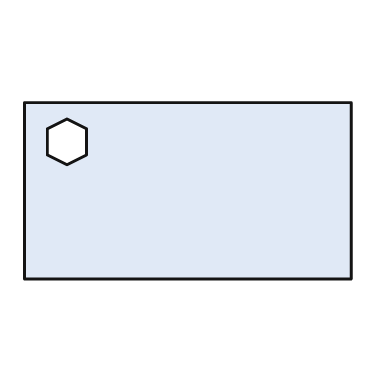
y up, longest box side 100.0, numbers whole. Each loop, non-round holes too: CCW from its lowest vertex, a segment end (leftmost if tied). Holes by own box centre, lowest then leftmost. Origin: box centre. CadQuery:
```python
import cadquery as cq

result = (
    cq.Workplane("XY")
    .moveTo(-50.0, -27.0)
    .lineTo(50.0, -27.0)
    .lineTo(50.0, 27.0)
    .lineTo(-50.0, 27.0)
    .close()
    .moveTo(-37.0, 8.0)
    .lineTo(-31.0, 11.0)
    .lineTo(-31.0, 19.0)
    .lineTo(-37.0, 22.0)
    .lineTo(-43.0, 19.0)
    .lineTo(-43.0, 11.0)
    .close()
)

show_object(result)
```